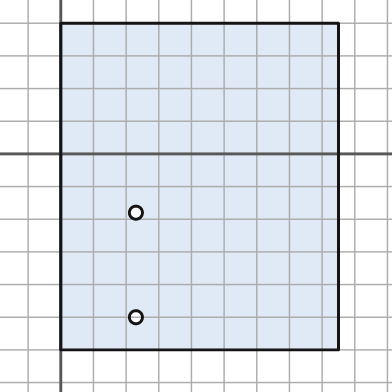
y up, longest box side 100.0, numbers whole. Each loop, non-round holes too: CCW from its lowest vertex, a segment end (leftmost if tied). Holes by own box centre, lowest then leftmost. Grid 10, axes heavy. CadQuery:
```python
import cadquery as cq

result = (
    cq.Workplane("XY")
    .moveTo(0.0, -60.0)
    .lineTo(85.0, -60.0)
    .lineTo(85.0, 40.0)
    .lineTo(0.0, 40.0)
    .close()
    .moveTo(23.0, -50.0)
    .circle(2.0)
    .moveTo(23.0, -18.0)
    .circle(2.0)
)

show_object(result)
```